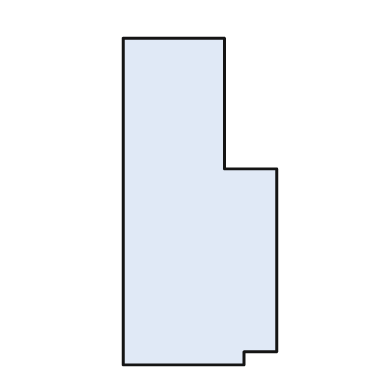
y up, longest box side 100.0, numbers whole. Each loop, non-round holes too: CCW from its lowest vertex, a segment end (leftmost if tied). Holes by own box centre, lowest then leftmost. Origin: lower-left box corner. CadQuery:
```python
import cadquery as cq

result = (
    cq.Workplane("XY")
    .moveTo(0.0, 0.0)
    .lineTo(37.0, 0.0)
    .lineTo(37.0, 4.0)
    .lineTo(47.0, 4.0)
    .lineTo(47.0, 60.0)
    .lineTo(31.0, 60.0)
    .lineTo(31.0, 100.0)
    .lineTo(0.0, 100.0)
    .close()
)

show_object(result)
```